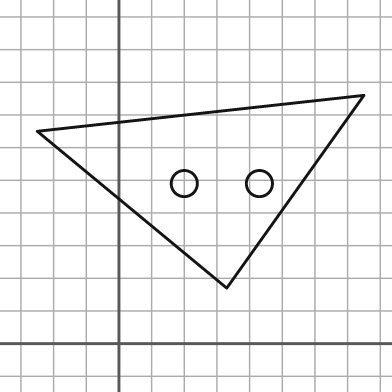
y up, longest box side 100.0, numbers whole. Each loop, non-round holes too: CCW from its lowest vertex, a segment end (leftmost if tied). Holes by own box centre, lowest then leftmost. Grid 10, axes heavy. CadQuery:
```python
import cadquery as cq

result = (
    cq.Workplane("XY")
    .moveTo(33.0, 17.0)
    .lineTo(75.0, 76.0)
    .lineTo(-25.0, 65.0)
    .close()
    .moveTo(20.0, 49.0)
    .circle(4.0)
    .moveTo(43.0, 49.0)
    .circle(4.0)
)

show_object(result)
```